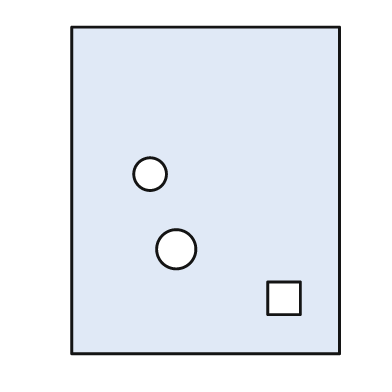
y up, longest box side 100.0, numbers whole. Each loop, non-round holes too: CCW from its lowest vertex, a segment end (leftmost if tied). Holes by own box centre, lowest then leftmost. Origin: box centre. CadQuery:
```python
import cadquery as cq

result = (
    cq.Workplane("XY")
    .moveTo(-41.0, -50.0)
    .lineTo(41.0, -50.0)
    .lineTo(41.0, 50.0)
    .lineTo(-41.0, 50.0)
    .close()
    .moveTo(19.0, -38.0)
    .lineTo(29.0, -38.0)
    .lineTo(29.0, -28.0)
    .lineTo(19.0, -28.0)
    .close()
    .moveTo(-9.0, -18.0)
    .circle(6.0)
    .moveTo(-17.0, 5.0)
    .circle(5.0)
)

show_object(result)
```